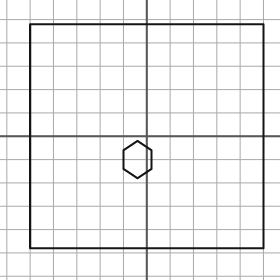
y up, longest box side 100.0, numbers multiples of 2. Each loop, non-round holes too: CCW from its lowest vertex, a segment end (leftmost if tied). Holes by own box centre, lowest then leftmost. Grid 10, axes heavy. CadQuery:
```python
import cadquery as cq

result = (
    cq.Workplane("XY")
    .moveTo(-50.0, -48.0)
    .lineTo(50.0, -48.0)
    .lineTo(50.0, 48.0)
    .lineTo(-50.0, 48.0)
    .close()
    .moveTo(-4.0, -18.0)
    .lineTo(2.0, -14.0)
    .lineTo(2.0, -6.0)
    .lineTo(-4.0, -2.0)
    .lineTo(-10.0, -6.0)
    .lineTo(-10.0, -14.0)
    .close()
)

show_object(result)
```